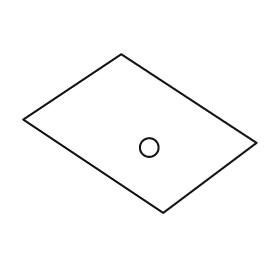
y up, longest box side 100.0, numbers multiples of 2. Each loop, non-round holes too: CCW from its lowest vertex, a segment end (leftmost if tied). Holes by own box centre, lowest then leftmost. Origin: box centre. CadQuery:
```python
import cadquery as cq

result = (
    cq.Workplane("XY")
    .moveTo(10.0, -34.0)
    .lineTo(50.0, -4.0)
    .lineTo(-8.0, 34.0)
    .lineTo(-50.0, 6.0)
    .close()
    .moveTo(4.0, -6.0)
    .circle(4.0)
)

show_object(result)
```